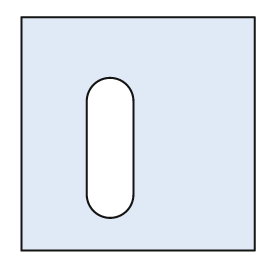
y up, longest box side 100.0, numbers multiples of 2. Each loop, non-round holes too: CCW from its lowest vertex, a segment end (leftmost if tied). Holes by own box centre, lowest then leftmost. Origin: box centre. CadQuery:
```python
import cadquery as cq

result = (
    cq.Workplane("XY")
    .moveTo(-50.0, -50.0)
    .lineTo(50.0, -50.0)
    .lineTo(50.0, 50.0)
    .lineTo(-50.0, 50.0)
    .close()
    .moveTo(-22.0, -26.0)
    .threePointArc((-12.0, -36.0), (-2.0, -26.0))
    .lineTo(-2.0, 14.0)
    .threePointArc((-12.0, 24.0), (-22.0, 14.0))
    .close()
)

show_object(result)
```